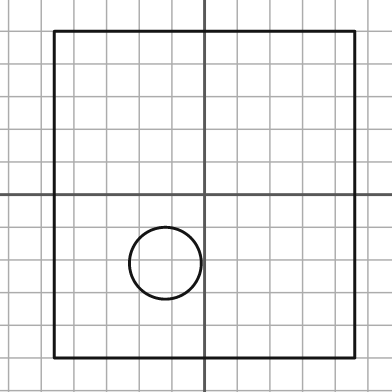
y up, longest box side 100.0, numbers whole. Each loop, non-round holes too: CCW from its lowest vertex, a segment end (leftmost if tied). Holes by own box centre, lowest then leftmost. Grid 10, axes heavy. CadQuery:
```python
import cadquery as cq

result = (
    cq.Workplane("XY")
    .moveTo(-46.0, -50.0)
    .lineTo(46.0, -50.0)
    .lineTo(46.0, 50.0)
    .lineTo(-46.0, 50.0)
    .close()
    .moveTo(-12.0, -21.0)
    .circle(11.0)
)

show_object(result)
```